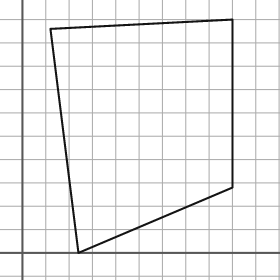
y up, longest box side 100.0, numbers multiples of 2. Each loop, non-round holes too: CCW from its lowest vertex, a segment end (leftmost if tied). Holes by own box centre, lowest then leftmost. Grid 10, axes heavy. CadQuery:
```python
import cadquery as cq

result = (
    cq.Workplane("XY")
    .moveTo(24.0, 0.0)
    .lineTo(90.0, 28.0)
    .lineTo(90.0, 100.0)
    .lineTo(12.0, 96.0)
    .close()
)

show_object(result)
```